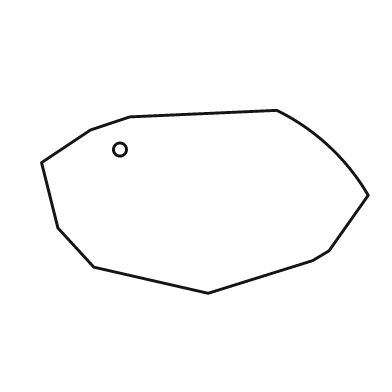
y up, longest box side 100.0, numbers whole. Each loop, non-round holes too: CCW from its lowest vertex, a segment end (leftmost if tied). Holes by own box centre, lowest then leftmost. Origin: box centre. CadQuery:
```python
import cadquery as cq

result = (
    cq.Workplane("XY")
    .moveTo(1.0, -28.0)
    .lineTo(33.0, -18.0)
    .lineTo(38.0, -15.0)
    .lineTo(50.0, 2.0)
    .threePointArc((38.0, 17.0), (22.0, 28.0))
    .lineTo(-23.0, 26.0)
    .lineTo(-35.0, 22.0)
    .lineTo(-50.0, 12.0)
    .lineTo(-45.0, -8.0)
    .lineTo(-34.0, -20.0)
    .close()
    .moveTo(-26.0, 16.0)
    .circle(2.0)
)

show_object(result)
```